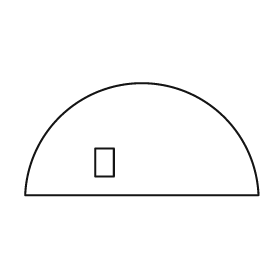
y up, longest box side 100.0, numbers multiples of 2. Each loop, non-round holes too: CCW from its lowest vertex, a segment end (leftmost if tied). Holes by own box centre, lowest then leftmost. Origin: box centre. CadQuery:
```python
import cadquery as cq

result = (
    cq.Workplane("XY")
    .moveTo(-50.0, -24.0)
    .lineTo(50.0, -24.0)
    .threePointArc((0.0, 24.0), (-50.0, -24.0))
    .close()
    .moveTo(-20.0, -16.0)
    .lineTo(-12.0, -16.0)
    .lineTo(-12.0, -4.0)
    .lineTo(-20.0, -4.0)
    .close()
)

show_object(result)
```